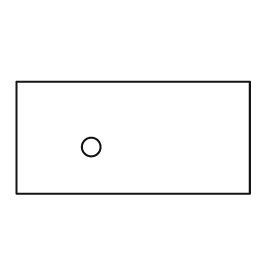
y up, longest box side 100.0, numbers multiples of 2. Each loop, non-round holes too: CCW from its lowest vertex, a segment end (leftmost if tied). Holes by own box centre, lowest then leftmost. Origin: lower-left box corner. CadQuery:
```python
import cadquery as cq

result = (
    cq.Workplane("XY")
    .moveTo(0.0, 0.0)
    .lineTo(100.0, 0.0)
    .lineTo(100.0, 48.0)
    .lineTo(0.0, 48.0)
    .close()
    .moveTo(32.0, 20.0)
    .circle(4.0)
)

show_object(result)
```